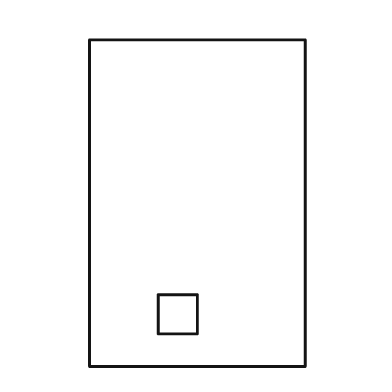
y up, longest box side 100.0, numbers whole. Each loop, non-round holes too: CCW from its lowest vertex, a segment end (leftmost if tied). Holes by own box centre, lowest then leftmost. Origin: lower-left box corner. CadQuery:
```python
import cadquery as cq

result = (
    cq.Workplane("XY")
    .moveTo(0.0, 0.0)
    .lineTo(66.0, 0.0)
    .lineTo(66.0, 100.0)
    .lineTo(0.0, 100.0)
    .close()
    .moveTo(21.0, 10.0)
    .lineTo(33.0, 10.0)
    .lineTo(33.0, 22.0)
    .lineTo(21.0, 22.0)
    .close()
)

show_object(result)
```